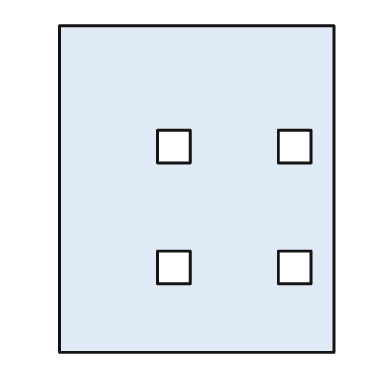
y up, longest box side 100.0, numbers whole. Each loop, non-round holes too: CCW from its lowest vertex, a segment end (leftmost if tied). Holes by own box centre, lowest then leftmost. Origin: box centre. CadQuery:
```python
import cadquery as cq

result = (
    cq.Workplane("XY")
    .moveTo(-42.0, -50.0)
    .lineTo(42.0, -50.0)
    .lineTo(42.0, 50.0)
    .lineTo(-42.0, 50.0)
    .close()
    .moveTo(-12.0, -29.0)
    .lineTo(-2.0, -29.0)
    .lineTo(-2.0, -19.0)
    .lineTo(-12.0, -19.0)
    .close()
    .moveTo(25.0, -29.0)
    .lineTo(35.0, -29.0)
    .lineTo(35.0, -19.0)
    .lineTo(25.0, -19.0)
    .close()
    .moveTo(-12.0, 8.0)
    .lineTo(-2.0, 8.0)
    .lineTo(-2.0, 18.0)
    .lineTo(-12.0, 18.0)
    .close()
    .moveTo(25.0, 8.0)
    .lineTo(35.0, 8.0)
    .lineTo(35.0, 18.0)
    .lineTo(25.0, 18.0)
    .close()
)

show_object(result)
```